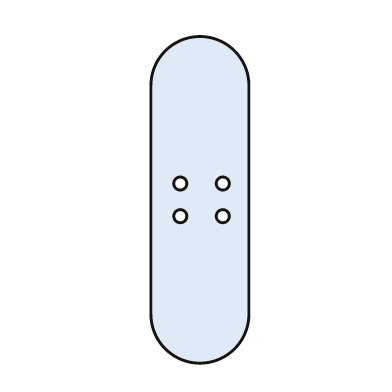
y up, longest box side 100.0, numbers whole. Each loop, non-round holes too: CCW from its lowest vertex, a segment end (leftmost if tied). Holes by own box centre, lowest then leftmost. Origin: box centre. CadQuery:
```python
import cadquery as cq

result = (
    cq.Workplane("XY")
    .moveTo(-15.0, -35.0)
    .threePointArc((0.0, -50.0), (15.0, -35.0))
    .lineTo(15.0, 35.0)
    .threePointArc((0.0, 50.0), (-15.0, 35.0))
    .close()
    .moveTo(-6.0, -5.0)
    .circle(2.0)
    .moveTo(7.0, -5.0)
    .circle(2.0)
    .moveTo(-6.0, 5.0)
    .circle(2.0)
    .moveTo(7.0, 5.0)
    .circle(2.0)
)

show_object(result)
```